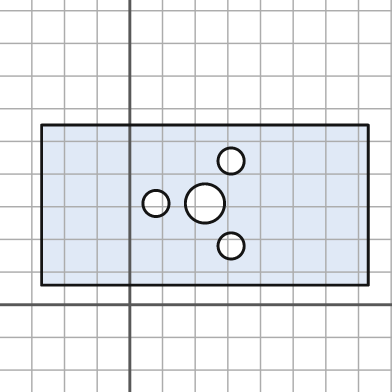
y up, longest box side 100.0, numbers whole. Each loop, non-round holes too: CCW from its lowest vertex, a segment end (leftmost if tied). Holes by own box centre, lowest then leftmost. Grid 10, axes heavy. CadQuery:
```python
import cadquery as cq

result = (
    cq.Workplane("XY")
    .moveTo(-27.0, 6.0)
    .lineTo(73.0, 6.0)
    .lineTo(73.0, 55.0)
    .lineTo(-27.0, 55.0)
    .close()
    .moveTo(31.0, 18.0)
    .circle(4.0)
    .moveTo(8.0, 31.0)
    .circle(4.0)
    .moveTo(23.0, 31.0)
    .circle(6.0)
    .moveTo(31.0, 44.0)
    .circle(4.0)
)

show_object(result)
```